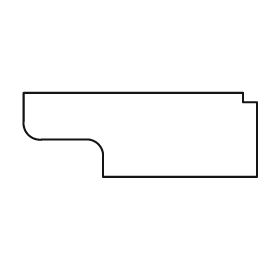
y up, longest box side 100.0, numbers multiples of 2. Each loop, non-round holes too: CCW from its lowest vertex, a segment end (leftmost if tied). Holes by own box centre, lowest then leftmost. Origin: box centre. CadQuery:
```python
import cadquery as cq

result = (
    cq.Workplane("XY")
    .moveTo(-16.0, -18.0)
    .lineTo(50.0, -18.0)
    .lineTo(50.0, 14.0)
    .lineTo(44.0, 14.0)
    .lineTo(44.0, 18.0)
    .lineTo(-50.0, 18.0)
    .lineTo(-50.0, 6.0)
    .threePointArc((-48.0, 0.0), (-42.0, -2.0))
    .lineTo(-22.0, -2.0)
    .threePointArc((-18.0, -4.0), (-16.0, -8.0))
    .close()
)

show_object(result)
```